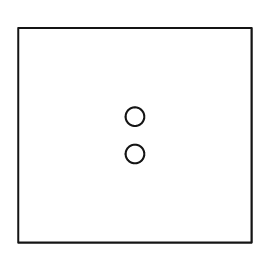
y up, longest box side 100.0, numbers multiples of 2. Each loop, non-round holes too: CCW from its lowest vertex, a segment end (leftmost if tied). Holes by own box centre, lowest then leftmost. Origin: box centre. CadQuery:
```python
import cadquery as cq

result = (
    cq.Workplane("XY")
    .moveTo(-50.0, -46.0)
    .lineTo(50.0, -46.0)
    .lineTo(50.0, 46.0)
    .lineTo(-50.0, 46.0)
    .close()
    .moveTo(0.0, -8.0)
    .circle(4.0)
    .moveTo(0.0, 8.0)
    .circle(4.0)
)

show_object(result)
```